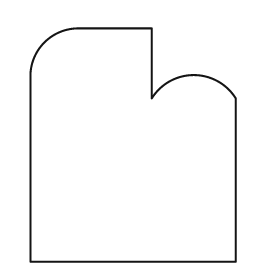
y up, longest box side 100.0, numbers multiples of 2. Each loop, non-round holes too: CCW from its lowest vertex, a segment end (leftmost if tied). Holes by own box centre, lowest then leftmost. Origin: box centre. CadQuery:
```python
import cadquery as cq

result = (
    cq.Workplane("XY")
    .moveTo(-44.0, -50.0)
    .lineTo(44.0, -50.0)
    .lineTo(44.0, 20.0)
    .threePointArc((26.0, 30.0), (8.0, 20.0))
    .lineTo(8.0, 50.0)
    .lineTo(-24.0, 50.0)
    .threePointArc((-38.0, 44.0), (-44.0, 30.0))
    .close()
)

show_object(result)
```